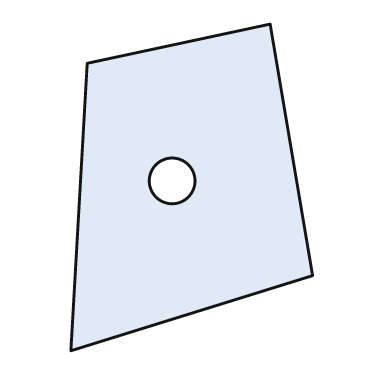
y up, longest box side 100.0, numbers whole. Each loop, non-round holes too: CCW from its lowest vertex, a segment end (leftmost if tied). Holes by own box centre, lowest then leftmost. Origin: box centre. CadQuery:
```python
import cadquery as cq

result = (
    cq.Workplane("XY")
    .moveTo(-37.0, -50.0)
    .lineTo(37.0, -27.0)
    .lineTo(24.0, 50.0)
    .lineTo(-32.0, 38.0)
    .close()
    .moveTo(-6.0, 2.0)
    .circle(7.0)
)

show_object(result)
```